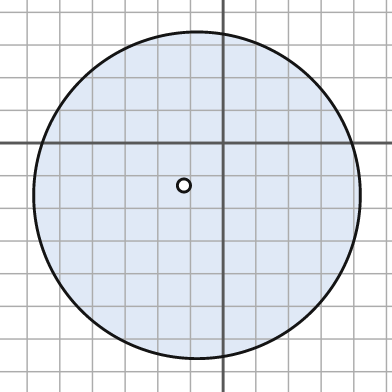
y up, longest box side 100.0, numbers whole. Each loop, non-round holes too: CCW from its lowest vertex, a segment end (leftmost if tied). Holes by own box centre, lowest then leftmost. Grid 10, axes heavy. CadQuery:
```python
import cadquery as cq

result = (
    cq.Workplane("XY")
    .moveTo(-8.0, -16.0)
    .circle(50.0)
    .moveTo(-12.0, -13.0)
    .circle(2.0)
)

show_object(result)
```